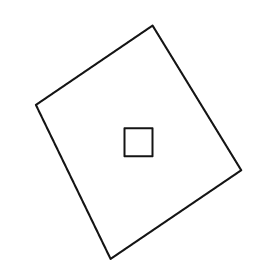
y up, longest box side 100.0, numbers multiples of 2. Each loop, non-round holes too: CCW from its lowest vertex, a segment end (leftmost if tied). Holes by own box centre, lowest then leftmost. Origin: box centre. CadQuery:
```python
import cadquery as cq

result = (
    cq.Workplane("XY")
    .moveTo(-12.0, -50.0)
    .lineTo(44.0, -12.0)
    .lineTo(6.0, 50.0)
    .lineTo(-44.0, 16.0)
    .close()
    .moveTo(-6.0, -6.0)
    .lineTo(6.0, -6.0)
    .lineTo(6.0, 6.0)
    .lineTo(-6.0, 6.0)
    .close()
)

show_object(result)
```